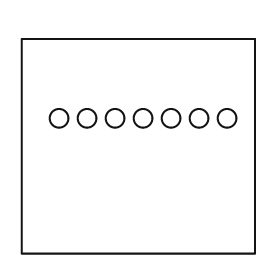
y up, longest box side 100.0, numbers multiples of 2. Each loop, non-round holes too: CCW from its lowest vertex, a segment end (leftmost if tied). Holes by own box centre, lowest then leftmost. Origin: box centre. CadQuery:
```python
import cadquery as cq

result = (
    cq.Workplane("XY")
    .moveTo(-50.0, -46.0)
    .lineTo(50.0, -46.0)
    .lineTo(50.0, 46.0)
    .lineTo(-50.0, 46.0)
    .close()
    .moveTo(-34.0, 12.0)
    .circle(4.0)
    .moveTo(-22.0, 12.0)
    .circle(4.0)
    .moveTo(-10.0, 12.0)
    .circle(4.0)
    .moveTo(2.0, 12.0)
    .circle(4.0)
    .moveTo(14.0, 12.0)
    .circle(4.0)
    .moveTo(26.0, 12.0)
    .circle(4.0)
    .moveTo(38.0, 12.0)
    .circle(4.0)
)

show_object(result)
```